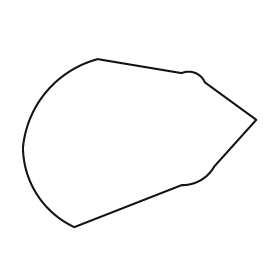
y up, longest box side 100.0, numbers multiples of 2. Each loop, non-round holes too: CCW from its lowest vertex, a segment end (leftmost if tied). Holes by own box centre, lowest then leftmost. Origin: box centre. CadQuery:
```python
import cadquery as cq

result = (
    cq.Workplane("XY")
    .moveTo(-28.0, -36.0)
    .lineTo(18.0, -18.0)
    .threePointArc((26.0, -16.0), (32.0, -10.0))
    .lineTo(50.0, 10.0)
    .lineTo(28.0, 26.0)
    .threePointArc((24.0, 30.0), (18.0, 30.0))
    .lineTo(-18.0, 36.0)
    .threePointArc((-40.0, 22.0), (-50.0, -2.0))
    .threePointArc((-44.0, -22.0), (-28.0, -36.0))
    .close()
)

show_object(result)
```